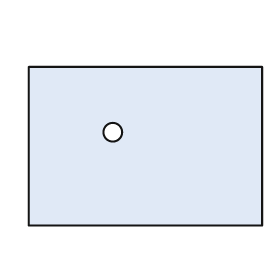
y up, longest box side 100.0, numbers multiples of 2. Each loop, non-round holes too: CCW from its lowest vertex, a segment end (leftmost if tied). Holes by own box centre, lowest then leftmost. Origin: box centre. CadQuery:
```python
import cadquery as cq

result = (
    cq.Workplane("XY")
    .moveTo(-50.0, -34.0)
    .lineTo(50.0, -34.0)
    .lineTo(50.0, 34.0)
    .lineTo(-50.0, 34.0)
    .close()
    .moveTo(-14.0, 6.0)
    .circle(4.0)
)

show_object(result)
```